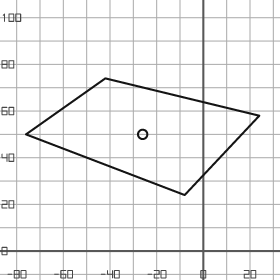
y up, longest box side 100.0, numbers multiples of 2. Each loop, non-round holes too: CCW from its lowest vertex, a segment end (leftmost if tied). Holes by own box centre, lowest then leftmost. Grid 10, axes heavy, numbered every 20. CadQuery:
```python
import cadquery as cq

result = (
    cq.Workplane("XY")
    .moveTo(-8.0, 24.0)
    .lineTo(24.0, 58.0)
    .lineTo(-42.0, 74.0)
    .lineTo(-76.0, 50.0)
    .close()
    .moveTo(-26.0, 50.0)
    .circle(2.0)
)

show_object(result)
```